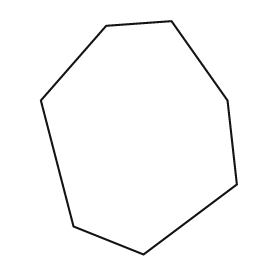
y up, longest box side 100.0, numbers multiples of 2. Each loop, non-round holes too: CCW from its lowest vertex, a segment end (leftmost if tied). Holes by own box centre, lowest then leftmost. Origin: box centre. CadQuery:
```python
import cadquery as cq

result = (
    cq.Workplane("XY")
    .moveTo(2.0, -50.0)
    .lineTo(42.0, -20.0)
    .lineTo(38.0, 16.0)
    .lineTo(14.0, 50.0)
    .lineTo(-14.0, 48.0)
    .lineTo(-42.0, 16.0)
    .lineTo(-28.0, -38.0)
    .close()
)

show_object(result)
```